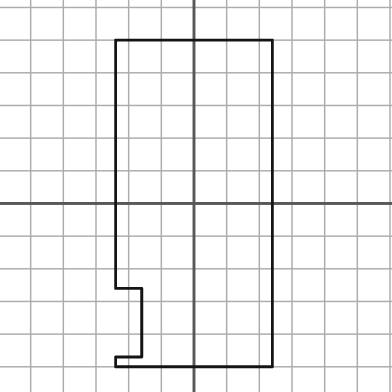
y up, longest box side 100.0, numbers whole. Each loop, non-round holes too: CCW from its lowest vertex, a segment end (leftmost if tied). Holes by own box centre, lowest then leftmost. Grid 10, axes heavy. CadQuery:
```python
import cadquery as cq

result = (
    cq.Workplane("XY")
    .moveTo(-24.0, -50.0)
    .lineTo(24.0, -50.0)
    .lineTo(24.0, 50.0)
    .lineTo(-24.0, 50.0)
    .lineTo(-24.0, -26.0)
    .lineTo(-16.0, -26.0)
    .lineTo(-16.0, -47.0)
    .lineTo(-24.0, -47.0)
    .close()
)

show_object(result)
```